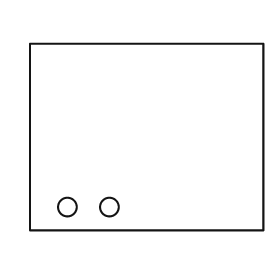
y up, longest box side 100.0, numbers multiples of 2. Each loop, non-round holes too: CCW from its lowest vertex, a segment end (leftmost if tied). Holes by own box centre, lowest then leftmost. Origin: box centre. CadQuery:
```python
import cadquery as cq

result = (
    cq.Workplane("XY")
    .moveTo(-50.0, -40.0)
    .lineTo(50.0, -40.0)
    .lineTo(50.0, 40.0)
    .lineTo(-50.0, 40.0)
    .close()
    .moveTo(-34.0, -30.0)
    .circle(4.0)
    .moveTo(-16.0, -30.0)
    .circle(4.0)
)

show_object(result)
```